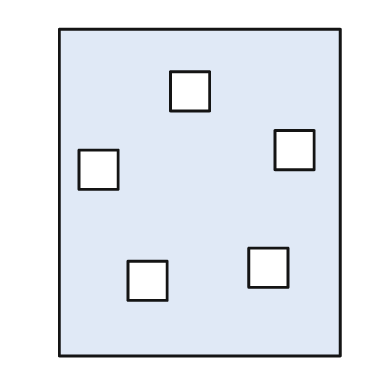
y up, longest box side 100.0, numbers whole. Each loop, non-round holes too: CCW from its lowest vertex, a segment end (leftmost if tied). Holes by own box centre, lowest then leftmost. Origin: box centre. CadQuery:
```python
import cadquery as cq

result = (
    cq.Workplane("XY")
    .moveTo(-43.0, -50.0)
    .lineTo(43.0, -50.0)
    .lineTo(43.0, 50.0)
    .lineTo(-43.0, 50.0)
    .close()
    .moveTo(-22.0, -33.0)
    .lineTo(-10.0, -33.0)
    .lineTo(-10.0, -21.0)
    .lineTo(-22.0, -21.0)
    .close()
    .moveTo(15.0, -29.0)
    .lineTo(27.0, -29.0)
    .lineTo(27.0, -17.0)
    .lineTo(15.0, -17.0)
    .close()
    .moveTo(-37.0, 1.0)
    .lineTo(-25.0, 1.0)
    .lineTo(-25.0, 13.0)
    .lineTo(-37.0, 13.0)
    .close()
    .moveTo(23.0, 7.0)
    .lineTo(35.0, 7.0)
    .lineTo(35.0, 19.0)
    .lineTo(23.0, 19.0)
    .close()
    .moveTo(-9.0, 25.0)
    .lineTo(3.0, 25.0)
    .lineTo(3.0, 37.0)
    .lineTo(-9.0, 37.0)
    .close()
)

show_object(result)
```